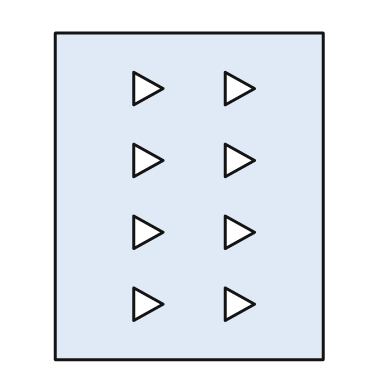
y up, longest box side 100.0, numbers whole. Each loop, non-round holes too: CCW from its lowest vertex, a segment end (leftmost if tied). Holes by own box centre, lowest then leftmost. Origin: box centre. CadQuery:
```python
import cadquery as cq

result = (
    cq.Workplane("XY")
    .moveTo(-41.0, -50.0)
    .lineTo(41.0, -50.0)
    .lineTo(41.0, 50.0)
    .lineTo(-41.0, 50.0)
    .close()
    .moveTo(-17.0, -38.0)
    .lineTo(-8.0, -33.0)
    .lineTo(-17.0, -28.0)
    .close()
    .moveTo(11.0, -38.0)
    .lineTo(20.0, -33.0)
    .lineTo(11.0, -28.0)
    .close()
    .moveTo(-17.0, -16.0)
    .lineTo(-8.0, -11.0)
    .lineTo(-17.0, -6.0)
    .close()
    .moveTo(11.0, -16.0)
    .lineTo(20.0, -11.0)
    .lineTo(11.0, -6.0)
    .close()
    .moveTo(-17.0, 6.0)
    .lineTo(-8.0, 11.0)
    .lineTo(-17.0, 16.0)
    .close()
    .moveTo(11.0, 6.0)
    .lineTo(20.0, 11.0)
    .lineTo(11.0, 16.0)
    .close()
    .moveTo(-17.0, 28.0)
    .lineTo(-8.0, 33.0)
    .lineTo(-17.0, 38.0)
    .close()
    .moveTo(11.0, 28.0)
    .lineTo(20.0, 33.0)
    .lineTo(11.0, 38.0)
    .close()
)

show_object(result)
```